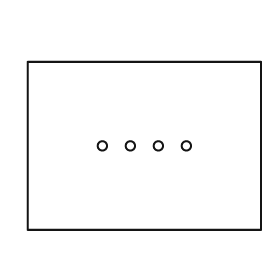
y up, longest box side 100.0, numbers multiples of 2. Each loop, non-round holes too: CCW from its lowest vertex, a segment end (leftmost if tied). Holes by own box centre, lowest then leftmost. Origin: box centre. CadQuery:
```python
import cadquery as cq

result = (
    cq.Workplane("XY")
    .moveTo(-50.0, -36.0)
    .lineTo(50.0, -36.0)
    .lineTo(50.0, 36.0)
    .lineTo(-50.0, 36.0)
    .close()
    .moveTo(-18.0, 0.0)
    .circle(2.0)
    .moveTo(-6.0, 0.0)
    .circle(2.0)
    .moveTo(6.0, 0.0)
    .circle(2.0)
    .moveTo(18.0, 0.0)
    .circle(2.0)
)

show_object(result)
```